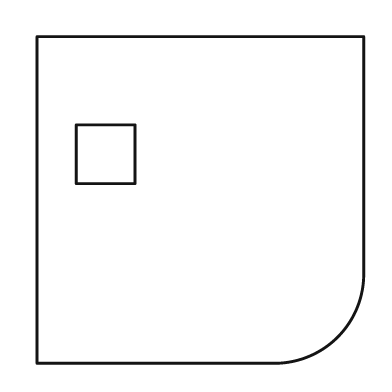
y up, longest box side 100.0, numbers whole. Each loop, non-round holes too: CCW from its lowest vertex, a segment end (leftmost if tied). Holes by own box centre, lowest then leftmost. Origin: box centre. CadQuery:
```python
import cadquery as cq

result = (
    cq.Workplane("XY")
    .moveTo(-50.0, -50.0)
    .lineTo(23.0, -50.0)
    .threePointArc((42.0, -42.0), (50.0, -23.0))
    .lineTo(50.0, 50.0)
    .lineTo(-50.0, 50.0)
    .close()
    .moveTo(-38.0, 5.0)
    .lineTo(-20.0, 5.0)
    .lineTo(-20.0, 23.0)
    .lineTo(-38.0, 23.0)
    .close()
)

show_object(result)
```